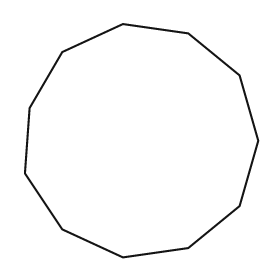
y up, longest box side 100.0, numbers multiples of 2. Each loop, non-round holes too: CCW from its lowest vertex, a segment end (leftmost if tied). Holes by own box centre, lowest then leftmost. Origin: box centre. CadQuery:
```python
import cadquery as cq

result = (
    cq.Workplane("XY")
    .moveTo(-8.0, -50.0)
    .lineTo(20.0, -46.0)
    .lineTo(42.0, -28.0)
    .lineTo(50.0, 0.0)
    .lineTo(42.0, 28.0)
    .lineTo(20.0, 46.0)
    .lineTo(-8.0, 50.0)
    .lineTo(-34.0, 38.0)
    .lineTo(-48.0, 14.0)
    .lineTo(-50.0, -14.0)
    .lineTo(-34.0, -38.0)
    .close()
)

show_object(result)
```